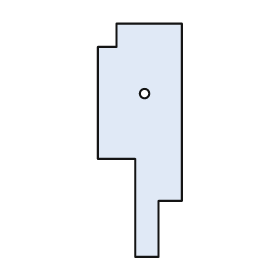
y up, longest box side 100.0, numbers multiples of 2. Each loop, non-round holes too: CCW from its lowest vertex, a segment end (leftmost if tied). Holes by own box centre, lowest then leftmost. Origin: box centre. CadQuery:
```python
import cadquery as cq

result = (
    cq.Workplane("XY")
    .moveTo(-2.0, -50.0)
    .lineTo(8.0, -50.0)
    .lineTo(8.0, -26.0)
    .lineTo(18.0, -26.0)
    .lineTo(18.0, 50.0)
    .lineTo(-10.0, 50.0)
    .lineTo(-10.0, 40.0)
    .lineTo(-18.0, 40.0)
    .lineTo(-18.0, -8.0)
    .lineTo(-2.0, -8.0)
    .close()
    .moveTo(2.0, 20.0)
    .circle(2.0)
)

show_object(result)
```